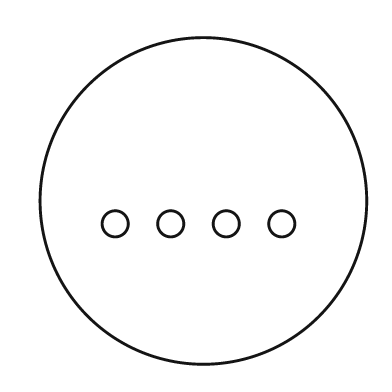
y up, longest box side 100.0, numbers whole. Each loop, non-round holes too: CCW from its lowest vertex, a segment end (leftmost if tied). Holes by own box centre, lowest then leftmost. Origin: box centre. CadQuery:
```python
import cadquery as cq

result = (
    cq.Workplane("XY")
    .moveTo(0.0, 0.0)
    .circle(50.0)
    .moveTo(-27.0, -7.0)
    .circle(4.0)
    .moveTo(-10.0, -7.0)
    .circle(4.0)
    .moveTo(7.0, -7.0)
    .circle(4.0)
    .moveTo(24.0, -7.0)
    .circle(4.0)
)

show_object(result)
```